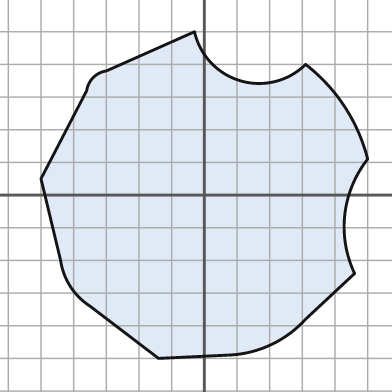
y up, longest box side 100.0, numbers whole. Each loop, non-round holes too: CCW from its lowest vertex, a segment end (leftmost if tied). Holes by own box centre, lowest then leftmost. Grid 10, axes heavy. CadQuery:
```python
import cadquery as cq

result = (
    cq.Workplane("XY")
    .moveTo(-14.0, -50.0)
    .lineTo(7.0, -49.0)
    .threePointArc((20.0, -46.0), (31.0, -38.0))
    .lineTo(46.0, -24.0)
    .threePointArc((43.0, -6.0), (50.0, 11.0))
    .threePointArc((43.0, 27.0), (31.0, 40.0))
    .threePointArc((11.0, 35.0), (-3.0, 50.0))
    .lineTo(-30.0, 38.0)
    .threePointArc((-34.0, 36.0), (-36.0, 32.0))
    .lineTo(-50.0, 5.0)
    .lineTo(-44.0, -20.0)
    .threePointArc((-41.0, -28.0), (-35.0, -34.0))
    .close()
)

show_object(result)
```